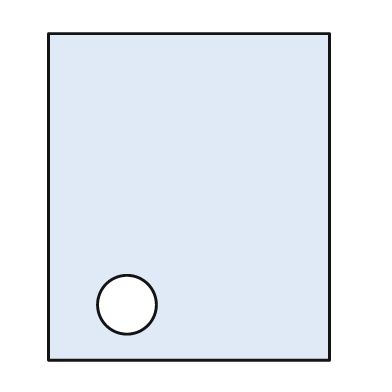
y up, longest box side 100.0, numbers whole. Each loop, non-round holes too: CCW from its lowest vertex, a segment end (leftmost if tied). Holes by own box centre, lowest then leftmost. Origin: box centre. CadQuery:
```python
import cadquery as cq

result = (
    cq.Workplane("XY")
    .moveTo(-43.0, -50.0)
    .lineTo(43.0, -50.0)
    .lineTo(43.0, 50.0)
    .lineTo(-43.0, 50.0)
    .close()
    .moveTo(-19.0, -33.0)
    .circle(9.0)
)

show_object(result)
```